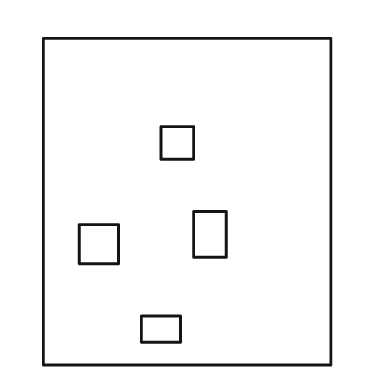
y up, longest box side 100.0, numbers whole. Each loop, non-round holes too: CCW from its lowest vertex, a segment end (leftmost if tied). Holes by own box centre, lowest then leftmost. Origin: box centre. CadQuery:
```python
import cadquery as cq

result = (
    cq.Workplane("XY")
    .moveTo(-44.0, -50.0)
    .lineTo(44.0, -50.0)
    .lineTo(44.0, 50.0)
    .lineTo(-44.0, 50.0)
    .close()
    .moveTo(-14.0, -43.0)
    .lineTo(-2.0, -43.0)
    .lineTo(-2.0, -35.0)
    .lineTo(-14.0, -35.0)
    .close()
    .moveTo(-33.0, -19.0)
    .lineTo(-21.0, -19.0)
    .lineTo(-21.0, -7.0)
    .lineTo(-33.0, -7.0)
    .close()
    .moveTo(2.0, -17.0)
    .lineTo(12.0, -17.0)
    .lineTo(12.0, -3.0)
    .lineTo(2.0, -3.0)
    .close()
    .moveTo(-8.0, 13.0)
    .lineTo(2.0, 13.0)
    .lineTo(2.0, 23.0)
    .lineTo(-8.0, 23.0)
    .close()
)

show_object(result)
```